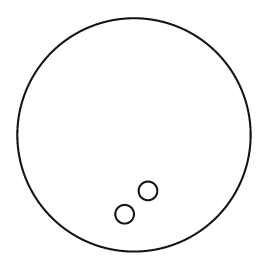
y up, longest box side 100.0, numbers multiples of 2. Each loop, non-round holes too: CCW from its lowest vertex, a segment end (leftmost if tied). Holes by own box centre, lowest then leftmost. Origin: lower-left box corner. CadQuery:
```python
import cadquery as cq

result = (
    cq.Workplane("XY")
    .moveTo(50.0, 50.0)
    .circle(50.0)
    .moveTo(46.0, 16.0)
    .circle(4.0)
    .moveTo(56.0, 26.0)
    .circle(4.0)
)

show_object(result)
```